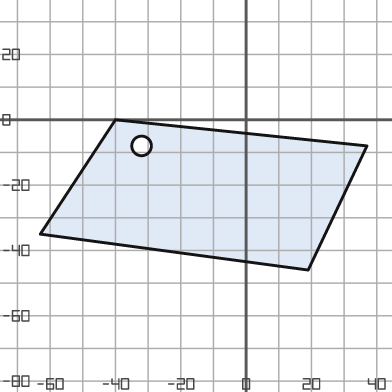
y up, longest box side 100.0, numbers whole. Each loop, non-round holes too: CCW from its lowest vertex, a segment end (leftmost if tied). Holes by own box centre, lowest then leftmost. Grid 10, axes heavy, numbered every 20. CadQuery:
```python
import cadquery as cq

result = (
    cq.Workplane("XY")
    .moveTo(19.0, -46.0)
    .lineTo(37.0, -8.0)
    .lineTo(-40.0, 0.0)
    .lineTo(-63.0, -35.0)
    .close()
    .moveTo(-32.0, -8.0)
    .circle(3.0)
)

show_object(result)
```